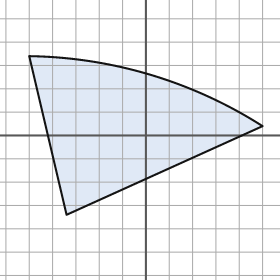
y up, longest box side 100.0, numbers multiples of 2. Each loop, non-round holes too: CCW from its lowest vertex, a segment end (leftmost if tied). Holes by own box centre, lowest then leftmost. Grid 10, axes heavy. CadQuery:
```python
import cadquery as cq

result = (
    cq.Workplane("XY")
    .moveTo(-34.0, -34.0)
    .lineTo(50.0, 4.0)
    .threePointArc((2.0, 26.0), (-50.0, 34.0))
    .close()
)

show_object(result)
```